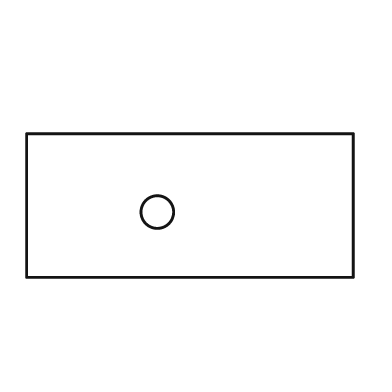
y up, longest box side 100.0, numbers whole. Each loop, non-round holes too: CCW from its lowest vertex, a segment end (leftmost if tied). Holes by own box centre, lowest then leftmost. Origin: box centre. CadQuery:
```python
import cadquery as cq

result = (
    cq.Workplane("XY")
    .moveTo(-50.0, -22.0)
    .lineTo(50.0, -22.0)
    .lineTo(50.0, 22.0)
    .lineTo(-50.0, 22.0)
    .close()
    .moveTo(-10.0, -2.0)
    .circle(5.0)
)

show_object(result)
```